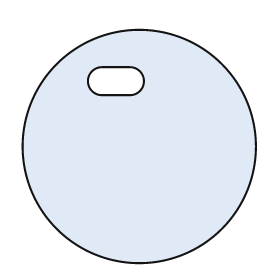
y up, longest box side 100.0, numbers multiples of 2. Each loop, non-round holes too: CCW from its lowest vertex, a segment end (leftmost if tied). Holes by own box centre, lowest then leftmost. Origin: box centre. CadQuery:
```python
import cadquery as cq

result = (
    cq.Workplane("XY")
    .moveTo(0.0, 0.0)
    .circle(50.0)
    .moveTo(-16.0, 22.0)
    .lineTo(-4.0, 22.0)
    .threePointArc((2.0, 28.0), (-4.0, 34.0))
    .lineTo(-16.0, 34.0)
    .threePointArc((-22.0, 28.0), (-16.0, 22.0))
    .close()
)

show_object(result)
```